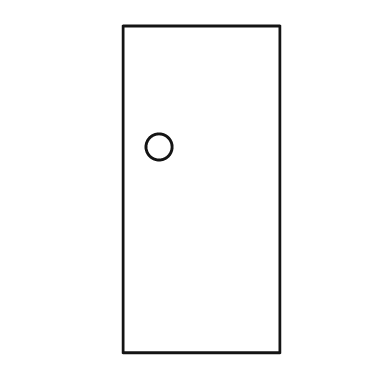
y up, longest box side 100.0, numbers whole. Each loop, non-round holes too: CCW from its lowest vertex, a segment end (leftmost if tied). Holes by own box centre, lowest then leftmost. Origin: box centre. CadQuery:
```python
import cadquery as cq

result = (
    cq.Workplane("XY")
    .moveTo(-24.0, -50.0)
    .lineTo(24.0, -50.0)
    .lineTo(24.0, 50.0)
    .lineTo(-24.0, 50.0)
    .close()
    .moveTo(-13.0, 13.0)
    .circle(4.0)
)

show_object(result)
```